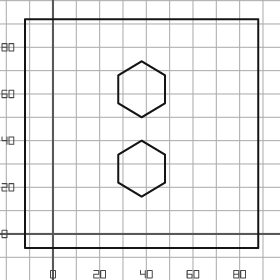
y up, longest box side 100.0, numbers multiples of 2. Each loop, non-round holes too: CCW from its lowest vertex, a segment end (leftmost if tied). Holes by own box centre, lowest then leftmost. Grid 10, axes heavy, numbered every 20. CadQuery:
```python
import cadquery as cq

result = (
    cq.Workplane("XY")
    .moveTo(-12.0, -6.0)
    .lineTo(88.0, -6.0)
    .lineTo(88.0, 92.0)
    .lineTo(-12.0, 92.0)
    .close()
    .moveTo(38.0, 16.0)
    .lineTo(48.0, 22.0)
    .lineTo(48.0, 34.0)
    .lineTo(38.0, 40.0)
    .lineTo(28.0, 34.0)
    .lineTo(28.0, 22.0)
    .close()
    .moveTo(38.0, 50.0)
    .lineTo(48.0, 56.0)
    .lineTo(48.0, 68.0)
    .lineTo(38.0, 74.0)
    .lineTo(28.0, 68.0)
    .lineTo(28.0, 56.0)
    .close()
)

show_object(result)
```